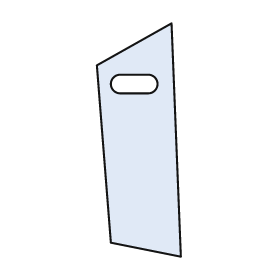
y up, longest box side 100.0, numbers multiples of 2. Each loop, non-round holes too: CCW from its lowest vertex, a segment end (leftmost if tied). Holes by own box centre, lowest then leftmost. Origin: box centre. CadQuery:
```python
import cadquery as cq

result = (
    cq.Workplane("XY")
    .moveTo(18.0, -50.0)
    .lineTo(14.0, 50.0)
    .lineTo(-18.0, 32.0)
    .lineTo(-12.0, -44.0)
    .close()
    .moveTo(-8.0, 20.0)
    .lineTo(4.0, 20.0)
    .threePointArc((8.0, 24.0), (4.0, 28.0))
    .lineTo(-8.0, 28.0)
    .threePointArc((-12.0, 24.0), (-8.0, 20.0))
    .close()
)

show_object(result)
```